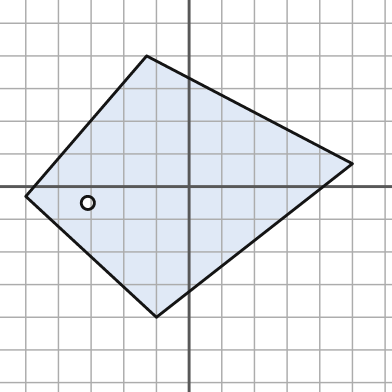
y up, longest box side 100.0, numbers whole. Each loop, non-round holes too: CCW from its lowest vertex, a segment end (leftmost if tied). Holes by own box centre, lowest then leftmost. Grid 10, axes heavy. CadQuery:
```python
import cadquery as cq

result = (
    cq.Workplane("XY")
    .moveTo(-10.0, -40.0)
    .lineTo(50.0, 7.0)
    .lineTo(-13.0, 40.0)
    .lineTo(-50.0, -3.0)
    .close()
    .moveTo(-31.0, -5.0)
    .circle(2.0)
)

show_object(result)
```